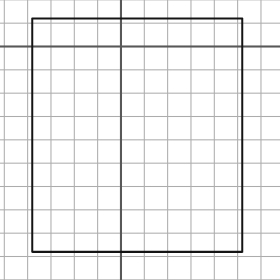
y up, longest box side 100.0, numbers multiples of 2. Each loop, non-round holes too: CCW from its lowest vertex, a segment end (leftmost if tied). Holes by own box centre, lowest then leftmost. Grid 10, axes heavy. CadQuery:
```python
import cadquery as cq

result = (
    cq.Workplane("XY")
    .moveTo(-38.0, -88.0)
    .lineTo(52.0, -88.0)
    .lineTo(52.0, 12.0)
    .lineTo(-38.0, 12.0)
    .close()
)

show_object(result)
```